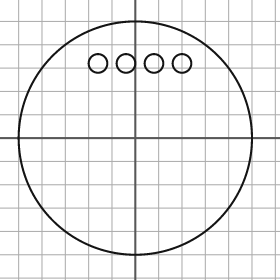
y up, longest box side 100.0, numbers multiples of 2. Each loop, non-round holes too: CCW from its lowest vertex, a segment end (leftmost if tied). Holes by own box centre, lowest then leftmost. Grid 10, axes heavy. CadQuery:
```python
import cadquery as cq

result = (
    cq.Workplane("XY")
    .moveTo(0.0, 0.0)
    .circle(50.0)
    .moveTo(-16.0, 32.0)
    .circle(4.0)
    .moveTo(-4.0, 32.0)
    .circle(4.0)
    .moveTo(8.0, 32.0)
    .circle(4.0)
    .moveTo(20.0, 32.0)
    .circle(4.0)
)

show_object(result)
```